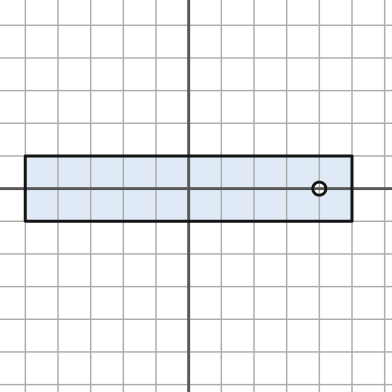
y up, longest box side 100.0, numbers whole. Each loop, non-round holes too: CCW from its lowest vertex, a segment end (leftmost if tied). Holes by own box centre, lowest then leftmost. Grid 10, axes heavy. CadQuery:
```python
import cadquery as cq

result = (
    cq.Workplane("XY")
    .moveTo(-50.0, -10.0)
    .lineTo(50.0, -10.0)
    .lineTo(50.0, 10.0)
    .lineTo(-50.0, 10.0)
    .close()
    .moveTo(40.0, 0.0)
    .circle(2.0)
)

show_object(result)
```